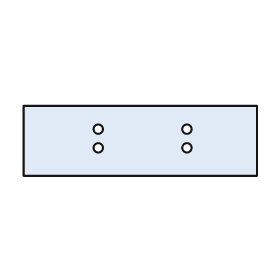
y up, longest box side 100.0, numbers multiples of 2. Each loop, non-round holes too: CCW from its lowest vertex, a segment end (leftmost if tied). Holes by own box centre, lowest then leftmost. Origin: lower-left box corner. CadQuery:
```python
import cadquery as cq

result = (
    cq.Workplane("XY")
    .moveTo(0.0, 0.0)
    .lineTo(100.0, 0.0)
    .lineTo(100.0, 30.0)
    .lineTo(0.0, 30.0)
    .close()
    .moveTo(32.0, 12.0)
    .circle(2.0)
    .moveTo(70.0, 12.0)
    .circle(2.0)
    .moveTo(32.0, 20.0)
    .circle(2.0)
    .moveTo(70.0, 20.0)
    .circle(2.0)
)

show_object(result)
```